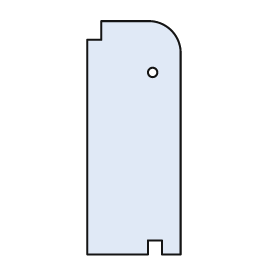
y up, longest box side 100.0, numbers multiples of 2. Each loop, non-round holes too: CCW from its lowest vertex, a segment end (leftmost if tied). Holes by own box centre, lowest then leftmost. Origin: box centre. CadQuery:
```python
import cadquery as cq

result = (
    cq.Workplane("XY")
    .moveTo(-20.0, -50.0)
    .lineTo(6.0, -50.0)
    .lineTo(6.0, -44.0)
    .lineTo(12.0, -44.0)
    .lineTo(12.0, -50.0)
    .lineTo(20.0, -50.0)
    .lineTo(20.0, 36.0)
    .threePointArc((16.0, 46.0), (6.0, 50.0))
    .lineTo(-14.0, 50.0)
    .lineTo(-14.0, 42.0)
    .lineTo(-20.0, 42.0)
    .close()
    .moveTo(8.0, 28.0)
    .circle(2.0)
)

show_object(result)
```